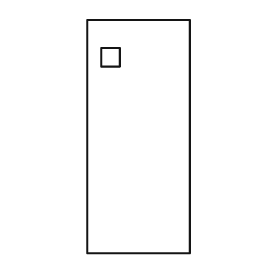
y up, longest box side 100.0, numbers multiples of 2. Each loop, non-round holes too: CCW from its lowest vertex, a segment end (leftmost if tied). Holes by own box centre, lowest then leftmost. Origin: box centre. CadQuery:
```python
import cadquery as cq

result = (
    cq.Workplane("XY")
    .moveTo(-22.0, -50.0)
    .lineTo(22.0, -50.0)
    .lineTo(22.0, 50.0)
    .lineTo(-22.0, 50.0)
    .close()
    .moveTo(-16.0, 30.0)
    .lineTo(-8.0, 30.0)
    .lineTo(-8.0, 38.0)
    .lineTo(-16.0, 38.0)
    .close()
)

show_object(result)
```